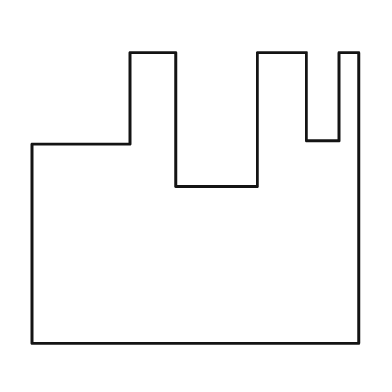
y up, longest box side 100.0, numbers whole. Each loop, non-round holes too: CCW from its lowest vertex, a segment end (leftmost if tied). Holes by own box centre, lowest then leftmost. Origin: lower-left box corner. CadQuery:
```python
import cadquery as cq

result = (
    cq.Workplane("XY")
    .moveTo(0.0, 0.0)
    .lineTo(100.0, 0.0)
    .lineTo(100.0, 89.0)
    .lineTo(94.0, 89.0)
    .lineTo(94.0, 62.0)
    .lineTo(84.0, 62.0)
    .lineTo(84.0, 89.0)
    .lineTo(69.0, 89.0)
    .lineTo(69.0, 48.0)
    .lineTo(44.0, 48.0)
    .lineTo(44.0, 89.0)
    .lineTo(30.0, 89.0)
    .lineTo(30.0, 61.0)
    .lineTo(0.0, 61.0)
    .close()
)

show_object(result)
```